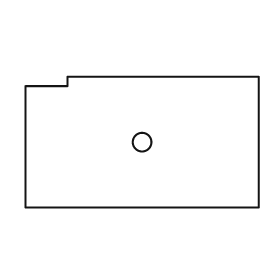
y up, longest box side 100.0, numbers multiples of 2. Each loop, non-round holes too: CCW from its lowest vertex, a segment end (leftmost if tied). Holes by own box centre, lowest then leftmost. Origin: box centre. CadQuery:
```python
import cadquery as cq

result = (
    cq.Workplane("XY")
    .moveTo(-50.0, -28.0)
    .lineTo(50.0, -28.0)
    .lineTo(50.0, 28.0)
    .lineTo(-32.0, 28.0)
    .lineTo(-32.0, 24.0)
    .lineTo(-50.0, 24.0)
    .close()
    .moveTo(0.0, 0.0)
    .circle(4.0)
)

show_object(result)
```